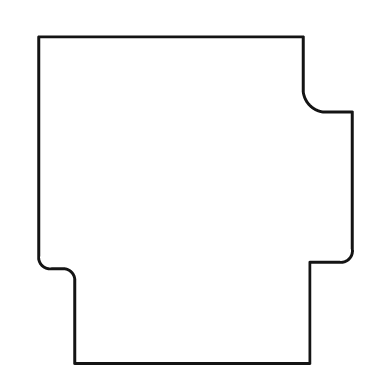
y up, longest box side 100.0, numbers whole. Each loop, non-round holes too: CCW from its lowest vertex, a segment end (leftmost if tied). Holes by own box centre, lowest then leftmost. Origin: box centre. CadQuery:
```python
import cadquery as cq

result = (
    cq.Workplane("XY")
    .moveTo(-37.0, -50.0)
    .lineTo(35.0, -50.0)
    .lineTo(35.0, -19.0)
    .lineTo(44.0, -19.0)
    .threePointArc((47.0, -18.0), (48.0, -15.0))
    .lineTo(48.0, 27.0)
    .lineTo(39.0, 27.0)
    .threePointArc((35.0, 29.0), (33.0, 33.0))
    .lineTo(33.0, 50.0)
    .lineTo(-48.0, 50.0)
    .lineTo(-48.0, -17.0)
    .threePointArc((-47.0, -20.0), (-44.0, -21.0))
    .lineTo(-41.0, -21.0)
    .threePointArc((-38.0, -22.0), (-37.0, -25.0))
    .close()
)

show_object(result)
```